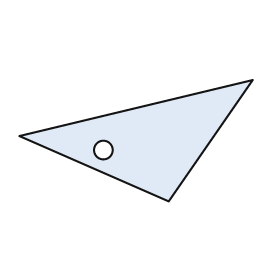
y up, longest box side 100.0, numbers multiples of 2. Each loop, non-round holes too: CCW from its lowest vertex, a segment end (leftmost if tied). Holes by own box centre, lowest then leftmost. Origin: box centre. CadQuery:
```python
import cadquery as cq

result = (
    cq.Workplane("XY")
    .moveTo(14.0, -26.0)
    .lineTo(50.0, 26.0)
    .lineTo(-50.0, 2.0)
    .close()
    .moveTo(-14.0, -4.0)
    .circle(4.0)
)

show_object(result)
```